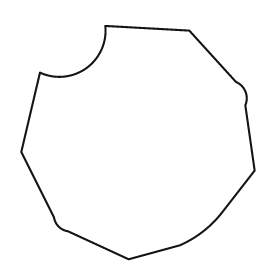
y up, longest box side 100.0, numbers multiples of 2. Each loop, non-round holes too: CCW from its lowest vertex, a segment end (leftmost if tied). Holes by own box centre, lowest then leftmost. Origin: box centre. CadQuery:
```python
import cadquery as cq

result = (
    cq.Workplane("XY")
    .moveTo(-4.0, -50.0)
    .lineTo(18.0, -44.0)
    .threePointArc((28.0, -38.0), (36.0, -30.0))
    .lineTo(50.0, -12.0)
    .lineTo(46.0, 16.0)
    .threePointArc((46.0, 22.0), (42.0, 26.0))
    .lineTo(22.0, 48.0)
    .lineTo(-14.0, 50.0)
    .threePointArc((-22.0, 32.0), (-42.0, 30.0))
    .lineTo(-50.0, -4.0)
    .lineTo(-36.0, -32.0)
    .threePointArc((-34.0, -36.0), (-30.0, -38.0))
    .close()
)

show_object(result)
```